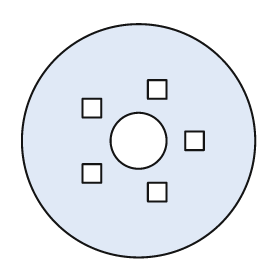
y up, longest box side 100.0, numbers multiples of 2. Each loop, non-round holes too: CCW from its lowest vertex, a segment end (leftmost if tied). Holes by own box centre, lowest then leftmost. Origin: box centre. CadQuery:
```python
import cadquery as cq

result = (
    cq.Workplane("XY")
    .moveTo(0.0, 0.0)
    .circle(50.0)
    .moveTo(4.0, -26.0)
    .lineTo(12.0, -26.0)
    .lineTo(12.0, -18.0)
    .lineTo(4.0, -18.0)
    .close()
    .moveTo(-24.0, -18.0)
    .lineTo(-16.0, -18.0)
    .lineTo(-16.0, -10.0)
    .lineTo(-24.0, -10.0)
    .close()
    .moveTo(0.0, 0.0)
    .circle(12.0)
    .moveTo(20.0, -4.0)
    .lineTo(28.0, -4.0)
    .lineTo(28.0, 4.0)
    .lineTo(20.0, 4.0)
    .close()
    .moveTo(-24.0, 10.0)
    .lineTo(-16.0, 10.0)
    .lineTo(-16.0, 18.0)
    .lineTo(-24.0, 18.0)
    .close()
    .moveTo(4.0, 18.0)
    .lineTo(12.0, 18.0)
    .lineTo(12.0, 26.0)
    .lineTo(4.0, 26.0)
    .close()
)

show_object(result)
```